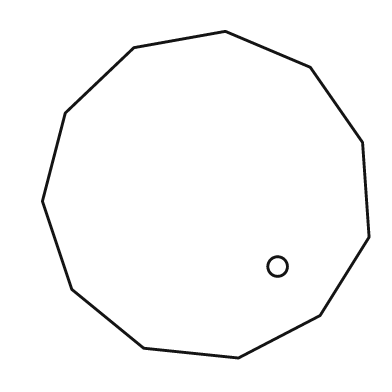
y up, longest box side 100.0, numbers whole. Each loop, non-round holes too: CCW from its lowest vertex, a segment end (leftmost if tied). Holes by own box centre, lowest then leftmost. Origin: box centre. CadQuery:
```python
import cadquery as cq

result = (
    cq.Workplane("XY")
    .moveTo(10.0, -50.0)
    .lineTo(35.0, -37.0)
    .lineTo(50.0, -13.0)
    .lineTo(48.0, 16.0)
    .lineTo(32.0, 39.0)
    .lineTo(6.0, 50.0)
    .lineTo(-22.0, 45.0)
    .lineTo(-43.0, 25.0)
    .lineTo(-50.0, -2.0)
    .lineTo(-41.0, -29.0)
    .lineTo(-19.0, -47.0)
    .close()
    .moveTo(22.0, -22.0)
    .circle(3.0)
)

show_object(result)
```